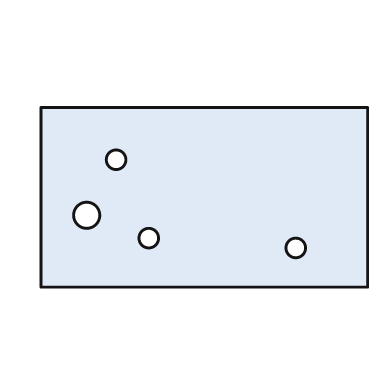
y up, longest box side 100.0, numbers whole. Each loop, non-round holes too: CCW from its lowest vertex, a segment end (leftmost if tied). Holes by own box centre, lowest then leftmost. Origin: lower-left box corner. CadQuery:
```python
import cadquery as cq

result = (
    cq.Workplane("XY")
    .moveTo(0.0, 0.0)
    .lineTo(100.0, 0.0)
    .lineTo(100.0, 55.0)
    .lineTo(0.0, 55.0)
    .close()
    .moveTo(78.0, 12.0)
    .circle(3.0)
    .moveTo(33.0, 15.0)
    .circle(3.0)
    .moveTo(14.0, 22.0)
    .circle(4.0)
    .moveTo(23.0, 39.0)
    .circle(3.0)
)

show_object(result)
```